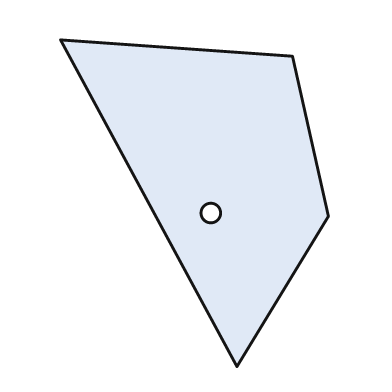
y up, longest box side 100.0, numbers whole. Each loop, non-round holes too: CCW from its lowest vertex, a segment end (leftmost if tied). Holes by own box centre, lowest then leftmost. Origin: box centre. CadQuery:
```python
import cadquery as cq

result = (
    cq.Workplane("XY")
    .moveTo(13.0, -50.0)
    .lineTo(41.0, -4.0)
    .lineTo(30.0, 45.0)
    .lineTo(-41.0, 50.0)
    .close()
    .moveTo(5.0, -3.0)
    .circle(3.0)
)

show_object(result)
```